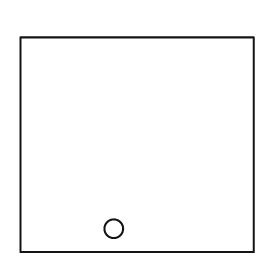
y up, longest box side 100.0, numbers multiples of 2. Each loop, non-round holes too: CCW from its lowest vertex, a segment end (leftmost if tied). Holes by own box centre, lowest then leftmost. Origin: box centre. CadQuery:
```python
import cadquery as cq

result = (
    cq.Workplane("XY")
    .moveTo(-50.0, -46.0)
    .lineTo(50.0, -46.0)
    .lineTo(50.0, 46.0)
    .lineTo(-50.0, 46.0)
    .close()
    .moveTo(-10.0, -36.0)
    .circle(4.0)
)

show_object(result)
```